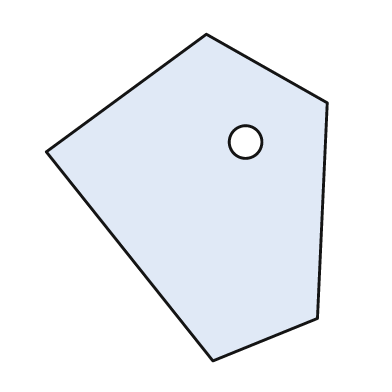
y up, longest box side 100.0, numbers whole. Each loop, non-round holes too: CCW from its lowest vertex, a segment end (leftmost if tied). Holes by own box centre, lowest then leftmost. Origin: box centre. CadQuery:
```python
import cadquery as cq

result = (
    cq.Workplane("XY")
    .moveTo(8.0, -50.0)
    .lineTo(40.0, -37.0)
    .lineTo(43.0, 29.0)
    .lineTo(6.0, 50.0)
    .lineTo(-43.0, 14.0)
    .close()
    .moveTo(18.0, 17.0)
    .circle(5.0)
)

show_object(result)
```